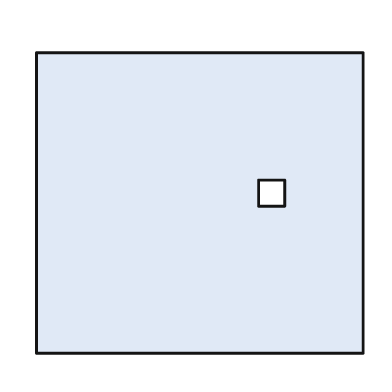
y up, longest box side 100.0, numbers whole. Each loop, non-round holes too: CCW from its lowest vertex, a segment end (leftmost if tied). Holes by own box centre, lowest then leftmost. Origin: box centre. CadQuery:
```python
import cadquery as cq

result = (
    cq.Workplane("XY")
    .moveTo(-50.0, -46.0)
    .lineTo(50.0, -46.0)
    .lineTo(50.0, 46.0)
    .lineTo(-50.0, 46.0)
    .close()
    .moveTo(18.0, -1.0)
    .lineTo(26.0, -1.0)
    .lineTo(26.0, 7.0)
    .lineTo(18.0, 7.0)
    .close()
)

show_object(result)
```